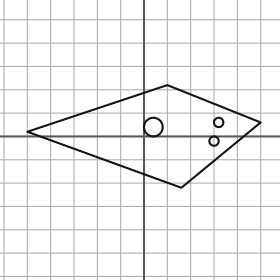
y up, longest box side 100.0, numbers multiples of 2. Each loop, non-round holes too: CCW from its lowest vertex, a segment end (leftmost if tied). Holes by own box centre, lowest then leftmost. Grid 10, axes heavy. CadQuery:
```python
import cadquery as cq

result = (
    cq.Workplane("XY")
    .moveTo(16.0, -22.0)
    .lineTo(50.0, 6.0)
    .lineTo(10.0, 22.0)
    .lineTo(-50.0, 2.0)
    .close()
    .moveTo(30.0, -2.0)
    .circle(2.0)
    .moveTo(4.0, 4.0)
    .circle(4.0)
    .moveTo(32.0, 6.0)
    .circle(2.0)
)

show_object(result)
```